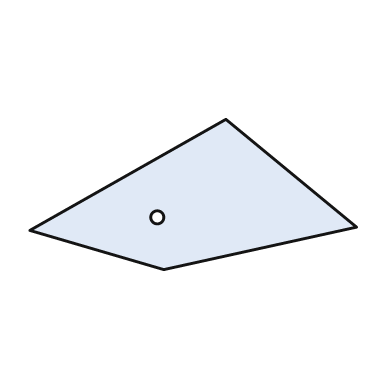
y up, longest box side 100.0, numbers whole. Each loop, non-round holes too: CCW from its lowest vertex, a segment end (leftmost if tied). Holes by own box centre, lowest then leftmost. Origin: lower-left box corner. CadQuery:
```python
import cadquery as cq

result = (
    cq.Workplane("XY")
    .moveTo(41.0, 0.0)
    .lineTo(100.0, 13.0)
    .lineTo(60.0, 46.0)
    .lineTo(0.0, 12.0)
    .close()
    .moveTo(39.0, 16.0)
    .circle(2.0)
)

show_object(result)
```